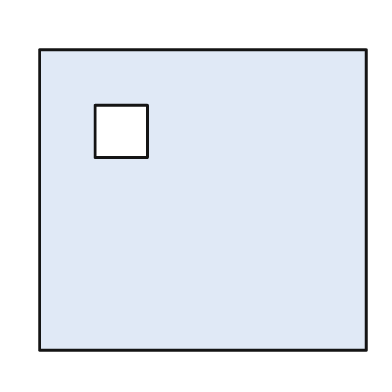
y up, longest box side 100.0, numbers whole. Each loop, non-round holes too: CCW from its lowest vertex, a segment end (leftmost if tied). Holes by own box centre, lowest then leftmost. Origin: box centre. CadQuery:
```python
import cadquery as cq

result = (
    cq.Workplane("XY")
    .moveTo(-50.0, -46.0)
    .lineTo(50.0, -46.0)
    .lineTo(50.0, 46.0)
    .lineTo(-50.0, 46.0)
    .close()
    .moveTo(-33.0, 13.0)
    .lineTo(-17.0, 13.0)
    .lineTo(-17.0, 29.0)
    .lineTo(-33.0, 29.0)
    .close()
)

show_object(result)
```